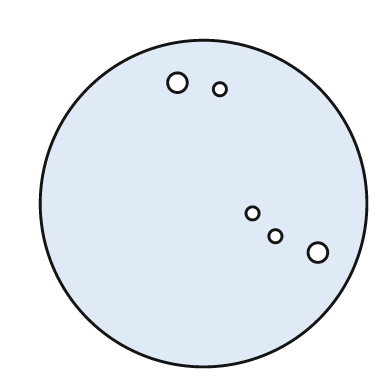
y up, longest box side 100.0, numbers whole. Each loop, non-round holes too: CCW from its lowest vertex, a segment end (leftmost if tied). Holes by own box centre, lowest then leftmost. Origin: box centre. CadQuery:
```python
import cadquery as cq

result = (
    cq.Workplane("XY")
    .moveTo(0.0, 0.0)
    .circle(50.0)
    .moveTo(35.0, -15.0)
    .circle(3.0)
    .moveTo(22.0, -10.0)
    .circle(2.0)
    .moveTo(15.0, -3.0)
    .circle(2.0)
    .moveTo(5.0, 35.0)
    .circle(2.0)
    .moveTo(-8.0, 37.0)
    .circle(3.0)
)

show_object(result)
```